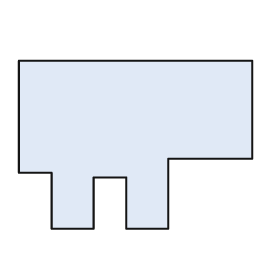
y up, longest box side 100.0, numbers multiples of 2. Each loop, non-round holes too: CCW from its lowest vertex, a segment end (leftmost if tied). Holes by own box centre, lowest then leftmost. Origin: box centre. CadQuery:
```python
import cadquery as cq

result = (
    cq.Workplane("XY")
    .moveTo(-36.0, -36.0)
    .lineTo(-18.0, -36.0)
    .lineTo(-18.0, -14.0)
    .lineTo(-4.0, -14.0)
    .lineTo(-4.0, -36.0)
    .lineTo(14.0, -36.0)
    .lineTo(14.0, -6.0)
    .lineTo(50.0, -6.0)
    .lineTo(50.0, 36.0)
    .lineTo(-50.0, 36.0)
    .lineTo(-50.0, -12.0)
    .lineTo(-36.0, -12.0)
    .close()
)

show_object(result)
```